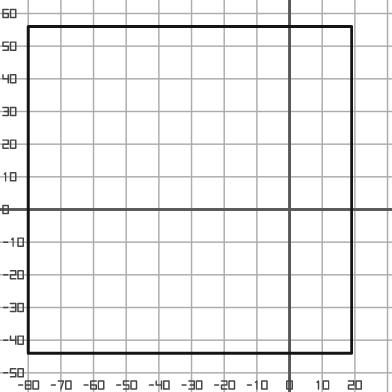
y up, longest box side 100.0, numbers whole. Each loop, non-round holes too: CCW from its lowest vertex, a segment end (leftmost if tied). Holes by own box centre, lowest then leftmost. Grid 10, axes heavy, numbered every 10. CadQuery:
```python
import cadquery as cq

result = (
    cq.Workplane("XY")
    .moveTo(-80.0, -44.0)
    .lineTo(19.0, -44.0)
    .lineTo(19.0, 56.0)
    .lineTo(-80.0, 56.0)
    .close()
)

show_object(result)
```